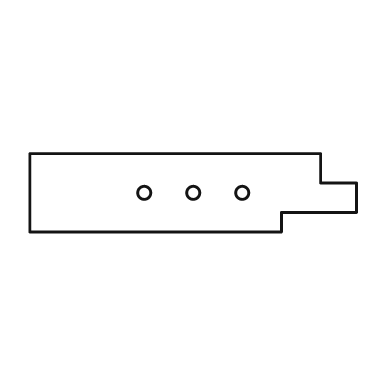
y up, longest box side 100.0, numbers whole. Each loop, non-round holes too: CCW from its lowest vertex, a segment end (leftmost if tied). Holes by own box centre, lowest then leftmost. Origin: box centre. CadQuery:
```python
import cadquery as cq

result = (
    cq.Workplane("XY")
    .moveTo(-50.0, -12.0)
    .lineTo(27.0, -12.0)
    .lineTo(27.0, -6.0)
    .lineTo(50.0, -6.0)
    .lineTo(50.0, 3.0)
    .lineTo(39.0, 3.0)
    .lineTo(39.0, 12.0)
    .lineTo(-50.0, 12.0)
    .close()
    .moveTo(-15.0, 0.0)
    .circle(2.0)
    .moveTo(0.0, 0.0)
    .circle(2.0)
    .moveTo(15.0, 0.0)
    .circle(2.0)
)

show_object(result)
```